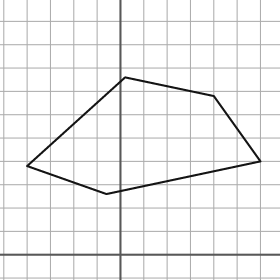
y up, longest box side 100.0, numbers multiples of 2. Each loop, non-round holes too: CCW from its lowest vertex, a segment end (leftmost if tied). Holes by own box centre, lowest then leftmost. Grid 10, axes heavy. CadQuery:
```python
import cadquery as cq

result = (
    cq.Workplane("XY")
    .moveTo(-6.0, 26.0)
    .lineTo(60.0, 40.0)
    .lineTo(40.0, 68.0)
    .lineTo(2.0, 76.0)
    .lineTo(-40.0, 38.0)
    .close()
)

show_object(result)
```